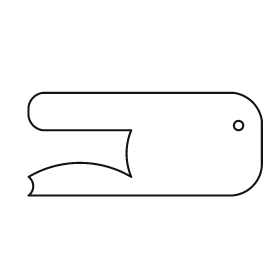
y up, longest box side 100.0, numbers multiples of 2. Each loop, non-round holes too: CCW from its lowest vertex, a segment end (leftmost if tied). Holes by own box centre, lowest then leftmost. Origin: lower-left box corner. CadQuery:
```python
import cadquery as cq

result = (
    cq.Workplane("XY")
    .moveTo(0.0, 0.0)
    .lineTo(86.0, 0.0)
    .threePointArc((96.0, 4.0), (100.0, 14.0))
    .lineTo(100.0, 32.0)
    .threePointArc((96.0, 40.0), (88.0, 44.0))
    .lineTo(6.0, 44.0)
    .threePointArc((2.0, 42.0), (0.0, 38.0))
    .lineTo(0.0, 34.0)
    .threePointArc((2.0, 30.0), (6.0, 28.0))
    .lineTo(44.0, 28.0)
    .threePointArc((42.0, 18.0), (44.0, 8.0))
    .threePointArc((22.0, 14.0), (0.0, 8.0))
    .threePointArc((2.0, 4.0), (0.0, 0.0))
    .close()
    .moveTo(90.0, 30.0)
    .circle(2.0)
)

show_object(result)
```